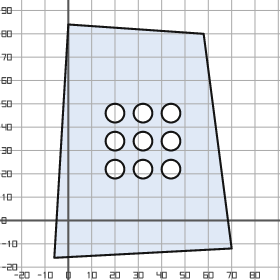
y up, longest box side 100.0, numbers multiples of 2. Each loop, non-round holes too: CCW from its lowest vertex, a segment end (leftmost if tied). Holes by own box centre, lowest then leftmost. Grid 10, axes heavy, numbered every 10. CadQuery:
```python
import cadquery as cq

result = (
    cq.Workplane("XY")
    .moveTo(-6.0, -16.0)
    .lineTo(70.0, -12.0)
    .lineTo(58.0, 80.0)
    .lineTo(0.0, 84.0)
    .close()
    .moveTo(20.0, 22.0)
    .circle(4.0)
    .moveTo(32.0, 22.0)
    .circle(4.0)
    .moveTo(44.0, 22.0)
    .circle(4.0)
    .moveTo(20.0, 34.0)
    .circle(4.0)
    .moveTo(32.0, 34.0)
    .circle(4.0)
    .moveTo(44.0, 34.0)
    .circle(4.0)
    .moveTo(20.0, 46.0)
    .circle(4.0)
    .moveTo(32.0, 46.0)
    .circle(4.0)
    .moveTo(44.0, 46.0)
    .circle(4.0)
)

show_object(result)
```